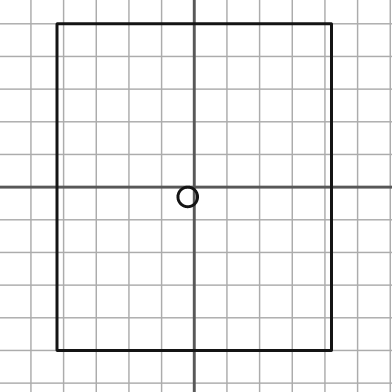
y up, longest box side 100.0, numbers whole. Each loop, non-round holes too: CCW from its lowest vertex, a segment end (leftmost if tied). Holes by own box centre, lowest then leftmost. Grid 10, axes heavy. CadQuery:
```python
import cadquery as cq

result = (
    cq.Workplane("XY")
    .moveTo(-42.0, -50.0)
    .lineTo(42.0, -50.0)
    .lineTo(42.0, 50.0)
    .lineTo(-42.0, 50.0)
    .close()
    .moveTo(-2.0, -3.0)
    .circle(3.0)
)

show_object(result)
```